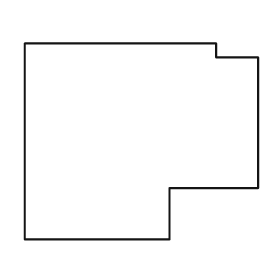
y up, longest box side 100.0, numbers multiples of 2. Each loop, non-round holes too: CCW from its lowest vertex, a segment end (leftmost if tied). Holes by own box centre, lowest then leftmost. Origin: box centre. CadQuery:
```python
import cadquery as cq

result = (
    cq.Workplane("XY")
    .moveTo(-50.0, -42.0)
    .lineTo(12.0, -42.0)
    .lineTo(12.0, -20.0)
    .lineTo(50.0, -20.0)
    .lineTo(50.0, 36.0)
    .lineTo(32.0, 36.0)
    .lineTo(32.0, 42.0)
    .lineTo(-50.0, 42.0)
    .close()
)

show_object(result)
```